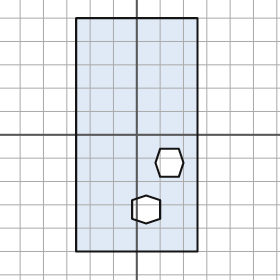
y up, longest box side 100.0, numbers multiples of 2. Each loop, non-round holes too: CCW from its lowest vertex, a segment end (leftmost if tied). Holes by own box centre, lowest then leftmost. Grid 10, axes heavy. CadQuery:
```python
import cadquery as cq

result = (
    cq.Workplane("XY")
    .moveTo(-26.0, -50.0)
    .lineTo(26.0, -50.0)
    .lineTo(26.0, 50.0)
    .lineTo(-26.0, 50.0)
    .close()
    .moveTo(4.0, -38.0)
    .lineTo(10.0, -36.0)
    .lineTo(10.0, -28.0)
    .lineTo(4.0, -26.0)
    .lineTo(-2.0, -28.0)
    .lineTo(-2.0, -36.0)
    .close()
    .moveTo(10.0, -18.0)
    .lineTo(18.0, -18.0)
    .lineTo(20.0, -12.0)
    .lineTo(18.0, -6.0)
    .lineTo(10.0, -6.0)
    .lineTo(8.0, -12.0)
    .close()
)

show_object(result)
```